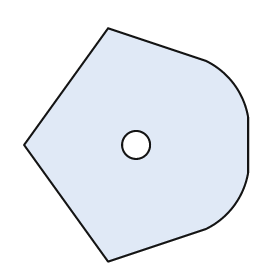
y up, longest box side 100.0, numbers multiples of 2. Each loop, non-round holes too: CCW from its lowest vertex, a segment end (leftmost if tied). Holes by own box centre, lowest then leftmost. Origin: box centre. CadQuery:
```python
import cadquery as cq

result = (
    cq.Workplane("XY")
    .moveTo(-12.0, -50.0)
    .lineTo(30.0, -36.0)
    .threePointArc((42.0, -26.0), (48.0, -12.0))
    .lineTo(48.0, 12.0)
    .threePointArc((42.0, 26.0), (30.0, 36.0))
    .lineTo(-12.0, 50.0)
    .lineTo(-48.0, 0.0)
    .close()
    .moveTo(0.0, 0.0)
    .circle(6.0)
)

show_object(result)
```